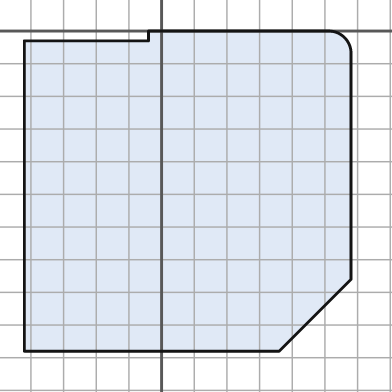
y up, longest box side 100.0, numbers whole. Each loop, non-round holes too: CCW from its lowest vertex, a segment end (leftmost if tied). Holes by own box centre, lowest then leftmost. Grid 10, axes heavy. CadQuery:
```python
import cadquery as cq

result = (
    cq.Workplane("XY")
    .moveTo(-42.0, -98.0)
    .lineTo(36.0, -98.0)
    .lineTo(58.0, -76.0)
    .lineTo(58.0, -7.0)
    .threePointArc((56.0, -2.0), (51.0, 0.0))
    .lineTo(-4.0, 0.0)
    .lineTo(-4.0, -3.0)
    .lineTo(-42.0, -3.0)
    .close()
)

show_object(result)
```